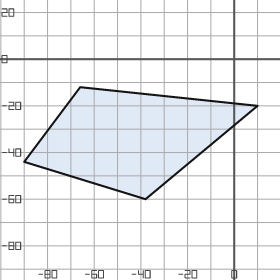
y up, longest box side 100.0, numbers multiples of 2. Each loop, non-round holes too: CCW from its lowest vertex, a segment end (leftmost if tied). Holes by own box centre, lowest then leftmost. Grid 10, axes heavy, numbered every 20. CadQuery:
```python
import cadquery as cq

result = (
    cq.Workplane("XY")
    .moveTo(-38.0, -60.0)
    .lineTo(10.0, -20.0)
    .lineTo(-66.0, -12.0)
    .lineTo(-90.0, -44.0)
    .close()
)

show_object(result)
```